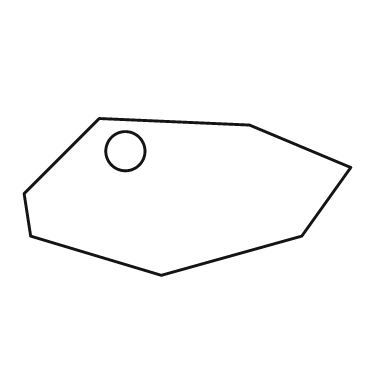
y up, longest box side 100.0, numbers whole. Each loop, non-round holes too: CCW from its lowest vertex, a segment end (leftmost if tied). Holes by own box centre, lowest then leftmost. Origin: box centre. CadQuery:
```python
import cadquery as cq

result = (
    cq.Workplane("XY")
    .moveTo(-8.0, -24.0)
    .lineTo(35.0, -12.0)
    .lineTo(50.0, 9.0)
    .lineTo(19.0, 22.0)
    .lineTo(-27.0, 24.0)
    .lineTo(-50.0, 1.0)
    .lineTo(-48.0, -12.0)
    .close()
    .moveTo(-19.0, 14.0)
    .circle(6.0)
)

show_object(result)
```